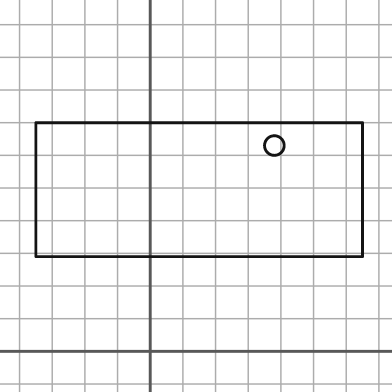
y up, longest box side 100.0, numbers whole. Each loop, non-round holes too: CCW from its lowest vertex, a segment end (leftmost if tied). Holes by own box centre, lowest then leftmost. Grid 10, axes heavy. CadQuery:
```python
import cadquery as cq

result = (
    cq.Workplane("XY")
    .moveTo(-35.0, 29.0)
    .lineTo(65.0, 29.0)
    .lineTo(65.0, 70.0)
    .lineTo(-35.0, 70.0)
    .close()
    .moveTo(38.0, 63.0)
    .circle(3.0)
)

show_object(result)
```